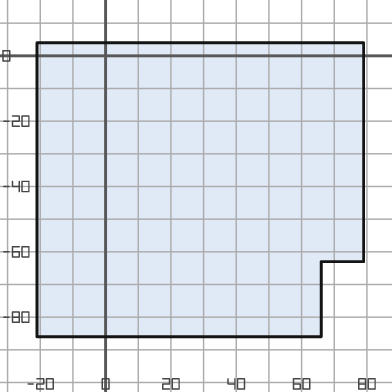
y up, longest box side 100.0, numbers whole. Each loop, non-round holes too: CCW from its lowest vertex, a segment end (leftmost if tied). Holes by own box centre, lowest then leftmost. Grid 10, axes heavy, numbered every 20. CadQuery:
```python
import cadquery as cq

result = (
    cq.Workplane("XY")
    .moveTo(-21.0, -86.0)
    .lineTo(66.0, -86.0)
    .lineTo(66.0, -63.0)
    .lineTo(79.0, -63.0)
    .lineTo(79.0, 4.0)
    .lineTo(-21.0, 4.0)
    .close()
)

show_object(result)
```